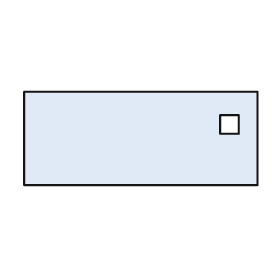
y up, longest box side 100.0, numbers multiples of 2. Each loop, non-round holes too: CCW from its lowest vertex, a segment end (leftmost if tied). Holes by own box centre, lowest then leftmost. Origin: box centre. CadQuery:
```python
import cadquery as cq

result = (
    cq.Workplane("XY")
    .moveTo(-50.0, -20.0)
    .lineTo(50.0, -20.0)
    .lineTo(50.0, 20.0)
    .lineTo(-50.0, 20.0)
    .close()
    .moveTo(34.0, 2.0)
    .lineTo(42.0, 2.0)
    .lineTo(42.0, 10.0)
    .lineTo(34.0, 10.0)
    .close()
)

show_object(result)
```